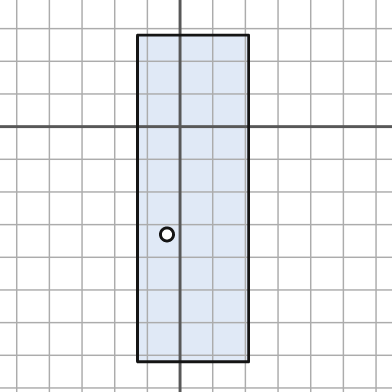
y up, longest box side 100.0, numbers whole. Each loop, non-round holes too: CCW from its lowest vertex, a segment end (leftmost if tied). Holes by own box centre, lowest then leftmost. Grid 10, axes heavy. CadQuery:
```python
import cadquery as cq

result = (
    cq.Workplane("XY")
    .moveTo(-13.0, -72.0)
    .lineTo(21.0, -72.0)
    .lineTo(21.0, 28.0)
    .lineTo(-13.0, 28.0)
    .close()
    .moveTo(-4.0, -33.0)
    .circle(2.0)
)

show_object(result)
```